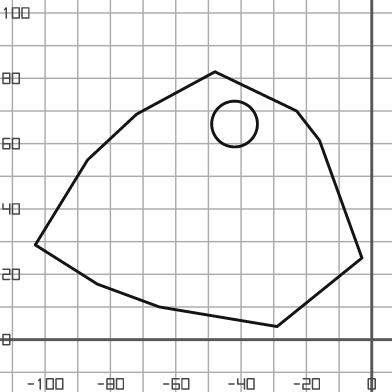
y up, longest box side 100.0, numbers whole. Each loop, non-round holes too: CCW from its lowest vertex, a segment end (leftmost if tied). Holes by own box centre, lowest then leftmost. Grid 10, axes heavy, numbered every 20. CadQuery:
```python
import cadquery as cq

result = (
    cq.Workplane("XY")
    .moveTo(-29.0, 4.0)
    .lineTo(-3.0, 25.0)
    .lineTo(-16.0, 61.0)
    .lineTo(-23.0, 70.0)
    .lineTo(-48.0, 82.0)
    .lineTo(-72.0, 69.0)
    .lineTo(-87.0, 55.0)
    .lineTo(-103.0, 29.0)
    .lineTo(-84.0, 17.0)
    .lineTo(-65.0, 10.0)
    .close()
    .moveTo(-42.0, 66.0)
    .circle(7.0)
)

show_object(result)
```